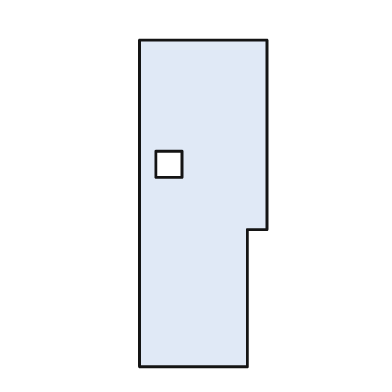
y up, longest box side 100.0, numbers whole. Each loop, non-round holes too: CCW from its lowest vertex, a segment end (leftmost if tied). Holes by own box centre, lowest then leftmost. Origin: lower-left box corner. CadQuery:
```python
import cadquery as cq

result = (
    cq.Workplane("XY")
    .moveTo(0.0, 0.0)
    .lineTo(33.0, 0.0)
    .lineTo(33.0, 42.0)
    .lineTo(39.0, 42.0)
    .lineTo(39.0, 100.0)
    .lineTo(0.0, 100.0)
    .close()
    .moveTo(5.0, 58.0)
    .lineTo(13.0, 58.0)
    .lineTo(13.0, 66.0)
    .lineTo(5.0, 66.0)
    .close()
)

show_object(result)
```